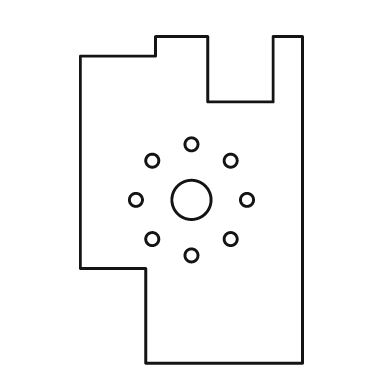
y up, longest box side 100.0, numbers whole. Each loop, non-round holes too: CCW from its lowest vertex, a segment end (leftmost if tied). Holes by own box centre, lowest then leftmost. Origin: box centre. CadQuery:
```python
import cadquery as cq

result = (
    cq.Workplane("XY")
    .moveTo(-14.0, -50.0)
    .lineTo(34.0, -50.0)
    .lineTo(34.0, 50.0)
    .lineTo(25.0, 50.0)
    .lineTo(25.0, 30.0)
    .lineTo(5.0, 30.0)
    .lineTo(5.0, 50.0)
    .lineTo(-11.0, 50.0)
    .lineTo(-11.0, 44.0)
    .lineTo(-34.0, 44.0)
    .lineTo(-34.0, -21.0)
    .lineTo(-14.0, -21.0)
    .close()
    .moveTo(0.0, -17.0)
    .circle(2.0)
    .moveTo(-12.0, -12.0)
    .circle(2.0)
    .moveTo(12.0, -12.0)
    .circle(2.0)
    .moveTo(-17.0, 0.0)
    .circle(2.0)
    .moveTo(0.0, 0.0)
    .circle(6.0)
    .moveTo(17.0, 0.0)
    .circle(2.0)
    .moveTo(-12.0, 12.0)
    .circle(2.0)
    .moveTo(12.0, 12.0)
    .circle(2.0)
    .moveTo(0.0, 17.0)
    .circle(2.0)
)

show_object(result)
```